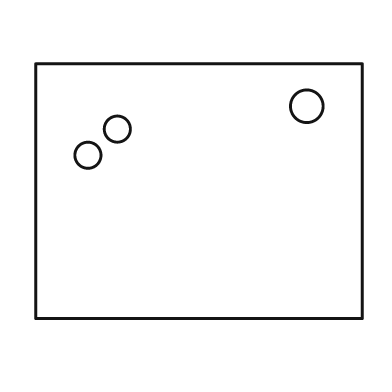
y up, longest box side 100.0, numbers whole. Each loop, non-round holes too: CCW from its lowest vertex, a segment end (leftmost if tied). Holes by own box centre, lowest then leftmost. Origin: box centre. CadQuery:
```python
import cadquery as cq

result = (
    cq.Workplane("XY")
    .moveTo(-50.0, -39.0)
    .lineTo(50.0, -39.0)
    .lineTo(50.0, 39.0)
    .lineTo(-50.0, 39.0)
    .close()
    .moveTo(-34.0, 11.0)
    .circle(4.0)
    .moveTo(-25.0, 19.0)
    .circle(4.0)
    .moveTo(33.0, 26.0)
    .circle(5.0)
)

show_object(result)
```